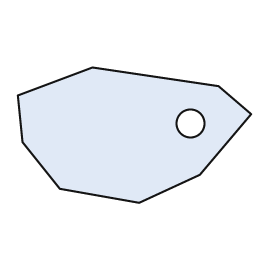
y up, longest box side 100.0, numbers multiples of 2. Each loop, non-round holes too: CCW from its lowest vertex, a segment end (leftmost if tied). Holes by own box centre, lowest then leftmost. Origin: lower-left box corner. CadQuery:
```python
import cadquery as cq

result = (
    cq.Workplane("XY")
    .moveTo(52.0, 0.0)
    .lineTo(78.0, 12.0)
    .lineTo(100.0, 38.0)
    .lineTo(86.0, 50.0)
    .lineTo(32.0, 58.0)
    .lineTo(0.0, 46.0)
    .lineTo(2.0, 26.0)
    .lineTo(18.0, 6.0)
    .close()
    .moveTo(74.0, 34.0)
    .circle(6.0)
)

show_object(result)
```